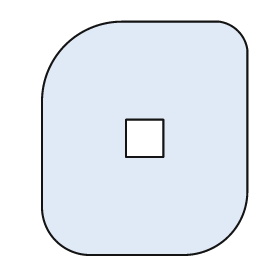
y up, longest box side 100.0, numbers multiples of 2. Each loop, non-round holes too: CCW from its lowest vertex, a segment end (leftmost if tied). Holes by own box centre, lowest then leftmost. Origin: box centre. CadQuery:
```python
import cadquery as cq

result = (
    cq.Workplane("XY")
    .moveTo(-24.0, -50.0)
    .lineTo(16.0, -50.0)
    .threePointArc((36.0, -42.0), (44.0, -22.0))
    .lineTo(44.0, 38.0)
    .threePointArc((40.0, 46.0), (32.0, 50.0))
    .lineTo(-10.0, 50.0)
    .threePointArc((-34.0, 40.0), (-44.0, 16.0))
    .lineTo(-44.0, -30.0)
    .threePointArc((-38.0, -44.0), (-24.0, -50.0))
    .close()
    .moveTo(-8.0, -8.0)
    .lineTo(8.0, -8.0)
    .lineTo(8.0, 8.0)
    .lineTo(-8.0, 8.0)
    .close()
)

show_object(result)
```